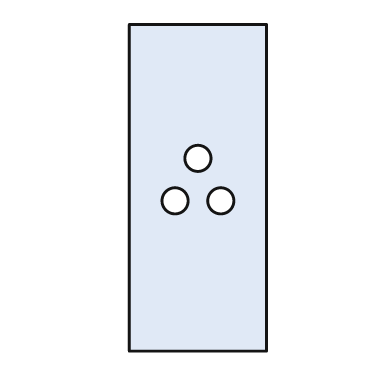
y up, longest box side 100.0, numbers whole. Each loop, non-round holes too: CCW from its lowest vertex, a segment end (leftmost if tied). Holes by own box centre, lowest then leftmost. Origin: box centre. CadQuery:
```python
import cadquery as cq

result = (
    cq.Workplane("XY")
    .moveTo(-21.0, -50.0)
    .lineTo(21.0, -50.0)
    .lineTo(21.0, 50.0)
    .lineTo(-21.0, 50.0)
    .close()
    .moveTo(-7.0, -4.0)
    .circle(4.0)
    .moveTo(7.0, -4.0)
    .circle(4.0)
    .moveTo(0.0, 9.0)
    .circle(4.0)
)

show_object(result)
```